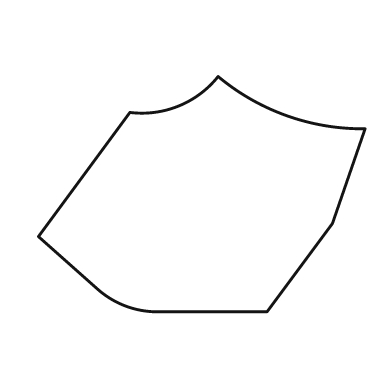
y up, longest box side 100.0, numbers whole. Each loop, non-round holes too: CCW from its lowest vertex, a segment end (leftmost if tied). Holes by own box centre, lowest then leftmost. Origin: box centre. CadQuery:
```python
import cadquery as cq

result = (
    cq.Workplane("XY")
    .moveTo(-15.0, -36.0)
    .lineTo(20.0, -36.0)
    .lineTo(40.0, -9.0)
    .lineTo(50.0, 20.0)
    .threePointArc((26.0, 24.0), (5.0, 36.0))
    .threePointArc((-7.0, 27.0), (-22.0, 25.0))
    .lineTo(-50.0, -13.0)
    .lineTo(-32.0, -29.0)
    .threePointArc((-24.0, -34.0), (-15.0, -36.0))
    .close()
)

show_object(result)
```